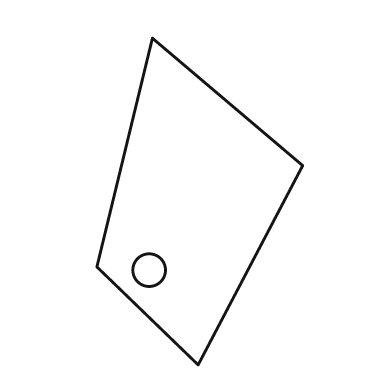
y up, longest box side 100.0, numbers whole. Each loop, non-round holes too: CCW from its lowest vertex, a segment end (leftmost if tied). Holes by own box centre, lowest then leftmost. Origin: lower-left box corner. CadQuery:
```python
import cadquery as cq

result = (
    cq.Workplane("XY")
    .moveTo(31.0, 0.0)
    .lineTo(63.0, 61.0)
    .lineTo(17.0, 100.0)
    .lineTo(0.0, 30.0)
    .close()
    .moveTo(16.0, 29.0)
    .circle(5.0)
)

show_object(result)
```